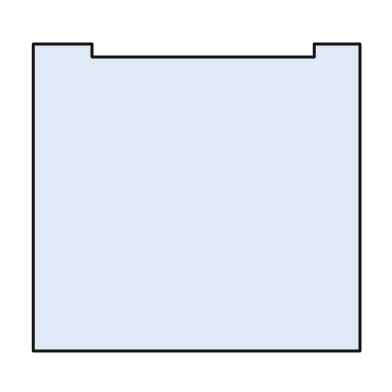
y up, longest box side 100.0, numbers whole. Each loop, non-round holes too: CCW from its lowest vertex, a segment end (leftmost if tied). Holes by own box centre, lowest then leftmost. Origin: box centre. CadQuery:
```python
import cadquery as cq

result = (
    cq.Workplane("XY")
    .moveTo(-50.0, -47.0)
    .lineTo(50.0, -47.0)
    .lineTo(50.0, 47.0)
    .lineTo(36.0, 47.0)
    .lineTo(36.0, 43.0)
    .lineTo(-32.0, 43.0)
    .lineTo(-32.0, 47.0)
    .lineTo(-50.0, 47.0)
    .close()
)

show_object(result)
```